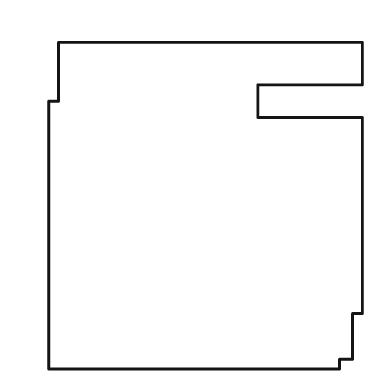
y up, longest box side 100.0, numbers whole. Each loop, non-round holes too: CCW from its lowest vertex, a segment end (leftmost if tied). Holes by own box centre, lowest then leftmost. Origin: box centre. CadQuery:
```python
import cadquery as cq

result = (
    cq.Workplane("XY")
    .moveTo(-48.0, -50.0)
    .lineTo(41.0, -50.0)
    .lineTo(41.0, -47.0)
    .lineTo(45.0, -47.0)
    .lineTo(45.0, -33.0)
    .lineTo(48.0, -33.0)
    .lineTo(48.0, 27.0)
    .lineTo(16.0, 27.0)
    .lineTo(16.0, 37.0)
    .lineTo(48.0, 37.0)
    .lineTo(48.0, 50.0)
    .lineTo(-45.0, 50.0)
    .lineTo(-45.0, 32.0)
    .lineTo(-48.0, 32.0)
    .close()
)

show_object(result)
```